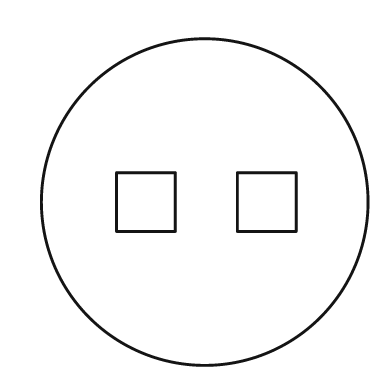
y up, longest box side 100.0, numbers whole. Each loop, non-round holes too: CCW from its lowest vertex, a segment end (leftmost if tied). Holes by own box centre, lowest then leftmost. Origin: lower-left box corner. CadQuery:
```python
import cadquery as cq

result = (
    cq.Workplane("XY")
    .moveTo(50.0, 50.0)
    .circle(50.0)
    .moveTo(23.0, 41.0)
    .lineTo(41.0, 41.0)
    .lineTo(41.0, 59.0)
    .lineTo(23.0, 59.0)
    .close()
    .moveTo(60.0, 41.0)
    .lineTo(78.0, 41.0)
    .lineTo(78.0, 59.0)
    .lineTo(60.0, 59.0)
    .close()
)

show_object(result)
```